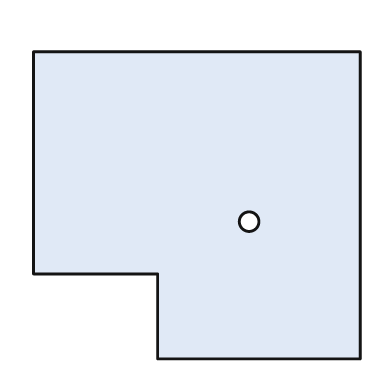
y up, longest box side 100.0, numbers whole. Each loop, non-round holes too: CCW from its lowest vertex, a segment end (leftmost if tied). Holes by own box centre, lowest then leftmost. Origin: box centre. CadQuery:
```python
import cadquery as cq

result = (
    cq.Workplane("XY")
    .moveTo(-12.0, -47.0)
    .lineTo(50.0, -47.0)
    .lineTo(50.0, 47.0)
    .lineTo(-50.0, 47.0)
    .lineTo(-50.0, -21.0)
    .lineTo(-12.0, -21.0)
    .close()
    .moveTo(16.0, -5.0)
    .circle(3.0)
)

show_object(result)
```